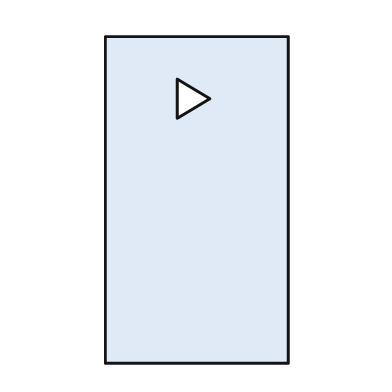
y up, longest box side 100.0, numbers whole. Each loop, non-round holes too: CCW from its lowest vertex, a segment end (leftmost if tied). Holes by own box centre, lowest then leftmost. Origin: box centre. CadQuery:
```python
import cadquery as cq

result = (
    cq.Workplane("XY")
    .moveTo(-28.0, -50.0)
    .lineTo(28.0, -50.0)
    .lineTo(28.0, 50.0)
    .lineTo(-28.0, 50.0)
    .close()
    .moveTo(-6.0, 25.0)
    .lineTo(4.0, 31.0)
    .lineTo(-6.0, 37.0)
    .close()
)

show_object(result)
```